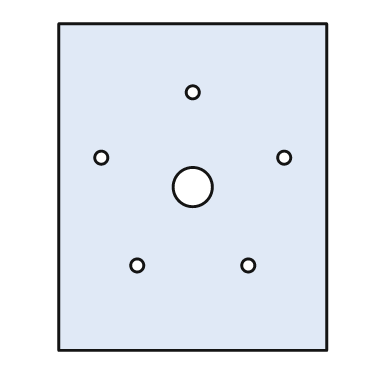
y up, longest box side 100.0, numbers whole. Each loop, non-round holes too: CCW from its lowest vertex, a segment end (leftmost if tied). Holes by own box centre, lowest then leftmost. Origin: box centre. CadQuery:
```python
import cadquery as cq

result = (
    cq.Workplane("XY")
    .moveTo(-41.0, -50.0)
    .lineTo(41.0, -50.0)
    .lineTo(41.0, 50.0)
    .lineTo(-41.0, 50.0)
    .close()
    .moveTo(-17.0, -24.0)
    .circle(2.0)
    .moveTo(17.0, -24.0)
    .circle(2.0)
    .moveTo(0.0, 0.0)
    .circle(6.0)
    .moveTo(-28.0, 9.0)
    .circle(2.0)
    .moveTo(28.0, 9.0)
    .circle(2.0)
    .moveTo(0.0, 29.0)
    .circle(2.0)
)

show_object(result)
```